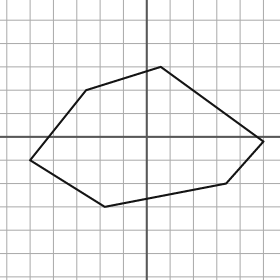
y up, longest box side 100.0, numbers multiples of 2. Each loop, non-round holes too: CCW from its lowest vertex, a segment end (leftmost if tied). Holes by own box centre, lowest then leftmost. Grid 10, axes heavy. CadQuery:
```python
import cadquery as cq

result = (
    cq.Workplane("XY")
    .moveTo(-18.0, -30.0)
    .lineTo(34.0, -20.0)
    .lineTo(50.0, -2.0)
    .lineTo(6.0, 30.0)
    .lineTo(-26.0, 20.0)
    .lineTo(-50.0, -10.0)
    .close()
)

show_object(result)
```